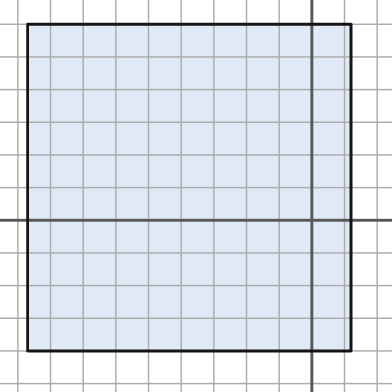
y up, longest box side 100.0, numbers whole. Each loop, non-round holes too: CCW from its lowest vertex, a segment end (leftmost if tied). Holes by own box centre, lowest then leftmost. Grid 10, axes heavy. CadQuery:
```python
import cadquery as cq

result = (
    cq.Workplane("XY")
    .moveTo(-87.0, -40.0)
    .lineTo(12.0, -40.0)
    .lineTo(12.0, 60.0)
    .lineTo(-87.0, 60.0)
    .close()
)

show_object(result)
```